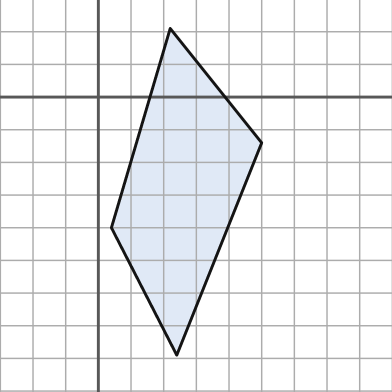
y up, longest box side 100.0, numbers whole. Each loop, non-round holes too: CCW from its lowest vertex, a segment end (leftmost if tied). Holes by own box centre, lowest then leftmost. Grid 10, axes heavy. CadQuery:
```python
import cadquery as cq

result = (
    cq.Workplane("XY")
    .moveTo(24.0, -79.0)
    .lineTo(50.0, -14.0)
    .lineTo(22.0, 21.0)
    .lineTo(4.0, -40.0)
    .close()
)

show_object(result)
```